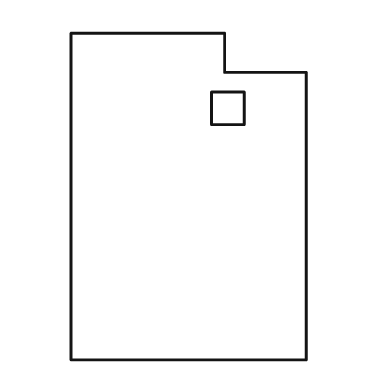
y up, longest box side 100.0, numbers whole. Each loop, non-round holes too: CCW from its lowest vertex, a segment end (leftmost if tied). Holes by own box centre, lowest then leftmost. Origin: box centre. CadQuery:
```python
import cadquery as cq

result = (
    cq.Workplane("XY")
    .moveTo(-36.0, -50.0)
    .lineTo(36.0, -50.0)
    .lineTo(36.0, 38.0)
    .lineTo(11.0, 38.0)
    .lineTo(11.0, 50.0)
    .lineTo(-36.0, 50.0)
    .close()
    .moveTo(7.0, 22.0)
    .lineTo(17.0, 22.0)
    .lineTo(17.0, 32.0)
    .lineTo(7.0, 32.0)
    .close()
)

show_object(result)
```